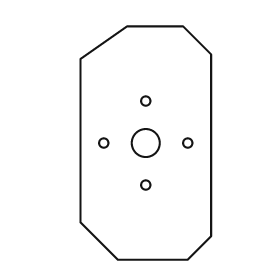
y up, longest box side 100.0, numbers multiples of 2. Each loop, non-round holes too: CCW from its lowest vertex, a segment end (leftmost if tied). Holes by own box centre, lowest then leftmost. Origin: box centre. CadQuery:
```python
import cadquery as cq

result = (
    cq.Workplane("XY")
    .moveTo(-12.0, -50.0)
    .lineTo(18.0, -50.0)
    .lineTo(28.0, -40.0)
    .lineTo(28.0, 38.0)
    .lineTo(16.0, 50.0)
    .lineTo(-8.0, 50.0)
    .lineTo(-28.0, 36.0)
    .lineTo(-28.0, -34.0)
    .close()
    .moveTo(0.0, -18.0)
    .circle(2.0)
    .moveTo(-18.0, 0.0)
    .circle(2.0)
    .moveTo(0.0, 0.0)
    .circle(6.0)
    .moveTo(18.0, 0.0)
    .circle(2.0)
    .moveTo(0.0, 18.0)
    .circle(2.0)
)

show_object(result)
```